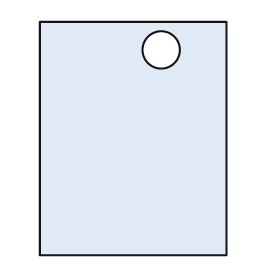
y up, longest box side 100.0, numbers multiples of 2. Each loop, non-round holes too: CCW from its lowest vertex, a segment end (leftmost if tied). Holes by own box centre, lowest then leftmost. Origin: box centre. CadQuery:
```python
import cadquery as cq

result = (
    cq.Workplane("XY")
    .moveTo(-40.0, -50.0)
    .lineTo(40.0, -50.0)
    .lineTo(40.0, 50.0)
    .lineTo(-40.0, 50.0)
    .close()
    .moveTo(12.0, 38.0)
    .circle(8.0)
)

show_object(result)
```